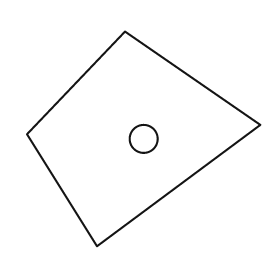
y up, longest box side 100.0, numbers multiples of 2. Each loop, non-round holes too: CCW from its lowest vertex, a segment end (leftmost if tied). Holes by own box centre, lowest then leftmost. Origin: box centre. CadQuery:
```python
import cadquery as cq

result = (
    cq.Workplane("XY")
    .moveTo(-20.0, -46.0)
    .lineTo(50.0, 6.0)
    .lineTo(-8.0, 46.0)
    .lineTo(-50.0, 2.0)
    .close()
    .moveTo(0.0, 0.0)
    .circle(6.0)
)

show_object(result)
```